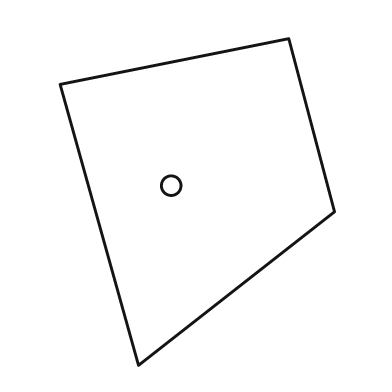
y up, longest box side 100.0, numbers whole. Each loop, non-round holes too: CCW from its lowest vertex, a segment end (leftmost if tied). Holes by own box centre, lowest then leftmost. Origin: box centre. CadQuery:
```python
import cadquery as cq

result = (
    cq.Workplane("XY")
    .moveTo(-18.0, -50.0)
    .lineTo(42.0, -3.0)
    .lineTo(28.0, 50.0)
    .lineTo(-42.0, 36.0)
    .close()
    .moveTo(-8.0, 5.0)
    .circle(3.0)
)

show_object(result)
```